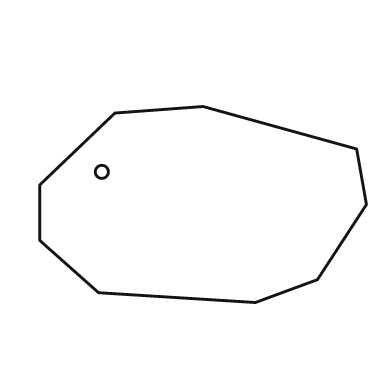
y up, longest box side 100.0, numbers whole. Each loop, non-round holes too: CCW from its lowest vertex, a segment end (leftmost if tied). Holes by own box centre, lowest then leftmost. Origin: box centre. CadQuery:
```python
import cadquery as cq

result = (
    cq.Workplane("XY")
    .moveTo(16.0, -30.0)
    .lineTo(35.0, -23.0)
    .lineTo(50.0, 0.0)
    .lineTo(47.0, 17.0)
    .lineTo(0.0, 30.0)
    .lineTo(-27.0, 28.0)
    .lineTo(-50.0, 6.0)
    .lineTo(-50.0, -11.0)
    .lineTo(-32.0, -27.0)
    .close()
    .moveTo(-31.0, 10.0)
    .circle(2.0)
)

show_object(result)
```